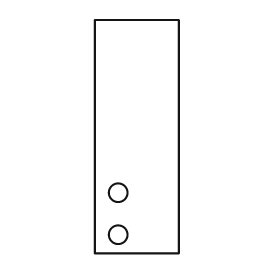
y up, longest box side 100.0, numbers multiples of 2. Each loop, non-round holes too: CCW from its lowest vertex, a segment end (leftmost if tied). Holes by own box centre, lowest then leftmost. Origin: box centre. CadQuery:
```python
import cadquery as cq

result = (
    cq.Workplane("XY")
    .moveTo(-18.0, -50.0)
    .lineTo(18.0, -50.0)
    .lineTo(18.0, 50.0)
    .lineTo(-18.0, 50.0)
    .close()
    .moveTo(-8.0, -42.0)
    .circle(4.0)
    .moveTo(-8.0, -24.0)
    .circle(4.0)
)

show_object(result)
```